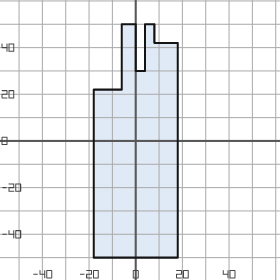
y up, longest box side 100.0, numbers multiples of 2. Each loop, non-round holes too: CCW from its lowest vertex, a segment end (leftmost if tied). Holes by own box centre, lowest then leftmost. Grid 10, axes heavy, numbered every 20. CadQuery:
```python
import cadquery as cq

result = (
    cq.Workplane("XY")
    .moveTo(-18.0, -50.0)
    .lineTo(18.0, -50.0)
    .lineTo(18.0, 42.0)
    .lineTo(8.0, 42.0)
    .lineTo(8.0, 50.0)
    .lineTo(4.0, 50.0)
    .lineTo(4.0, 30.0)
    .lineTo(0.0, 30.0)
    .lineTo(0.0, 50.0)
    .lineTo(-6.0, 50.0)
    .lineTo(-6.0, 22.0)
    .lineTo(-18.0, 22.0)
    .close()
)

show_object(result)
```